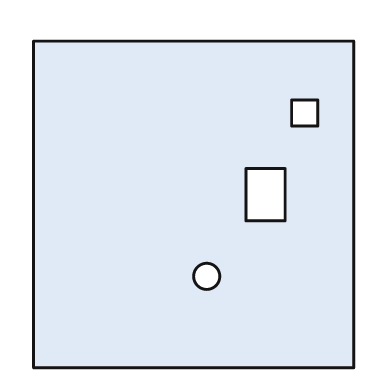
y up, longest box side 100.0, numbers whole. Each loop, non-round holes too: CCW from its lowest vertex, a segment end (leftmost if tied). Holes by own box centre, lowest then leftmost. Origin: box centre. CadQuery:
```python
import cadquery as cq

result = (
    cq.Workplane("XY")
    .moveTo(-49.0, -50.0)
    .lineTo(49.0, -50.0)
    .lineTo(49.0, 50.0)
    .lineTo(-49.0, 50.0)
    .close()
    .moveTo(4.0, -22.0)
    .circle(4.0)
    .moveTo(16.0, -5.0)
    .lineTo(28.0, -5.0)
    .lineTo(28.0, 11.0)
    .lineTo(16.0, 11.0)
    .close()
    .moveTo(30.0, 24.0)
    .lineTo(38.0, 24.0)
    .lineTo(38.0, 32.0)
    .lineTo(30.0, 32.0)
    .close()
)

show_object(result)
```